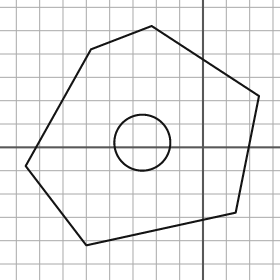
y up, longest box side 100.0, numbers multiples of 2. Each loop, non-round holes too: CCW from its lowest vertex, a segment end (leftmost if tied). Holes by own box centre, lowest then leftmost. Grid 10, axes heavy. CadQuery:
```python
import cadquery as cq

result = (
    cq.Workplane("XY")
    .moveTo(-50.0, -42.0)
    .lineTo(14.0, -28.0)
    .lineTo(24.0, 22.0)
    .lineTo(-22.0, 52.0)
    .lineTo(-48.0, 42.0)
    .lineTo(-76.0, -8.0)
    .close()
    .moveTo(-26.0, 2.0)
    .circle(12.0)
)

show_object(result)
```